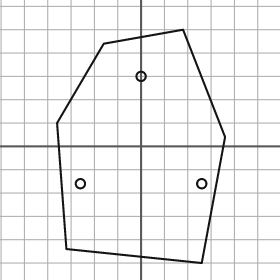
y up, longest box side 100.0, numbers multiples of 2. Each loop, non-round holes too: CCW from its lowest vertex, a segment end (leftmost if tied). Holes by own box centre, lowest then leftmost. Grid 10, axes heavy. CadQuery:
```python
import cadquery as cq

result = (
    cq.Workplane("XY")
    .moveTo(26.0, -50.0)
    .lineTo(36.0, 4.0)
    .lineTo(18.0, 50.0)
    .lineTo(-16.0, 44.0)
    .lineTo(-36.0, 10.0)
    .lineTo(-32.0, -44.0)
    .close()
    .moveTo(-26.0, -16.0)
    .circle(2.0)
    .moveTo(26.0, -16.0)
    .circle(2.0)
    .moveTo(0.0, 30.0)
    .circle(2.0)
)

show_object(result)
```